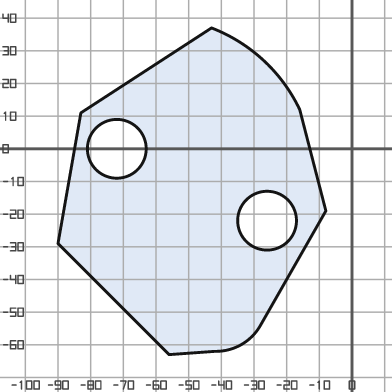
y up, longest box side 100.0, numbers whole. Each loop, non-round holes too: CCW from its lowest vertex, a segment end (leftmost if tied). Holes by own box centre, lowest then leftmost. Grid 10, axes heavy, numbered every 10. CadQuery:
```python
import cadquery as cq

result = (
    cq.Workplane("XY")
    .moveTo(-56.0, -63.0)
    .lineTo(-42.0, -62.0)
    .threePointArc((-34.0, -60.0), (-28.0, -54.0))
    .lineTo(-8.0, -19.0)
    .lineTo(-16.0, 12.0)
    .threePointArc((-27.0, 27.0), (-43.0, 37.0))
    .lineTo(-83.0, 11.0)
    .lineTo(-90.0, -29.0)
    .close()
    .moveTo(-26.0, -22.0)
    .circle(9.0)
    .moveTo(-72.0, 0.0)
    .circle(9.0)
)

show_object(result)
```